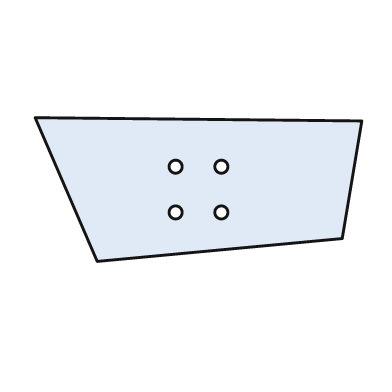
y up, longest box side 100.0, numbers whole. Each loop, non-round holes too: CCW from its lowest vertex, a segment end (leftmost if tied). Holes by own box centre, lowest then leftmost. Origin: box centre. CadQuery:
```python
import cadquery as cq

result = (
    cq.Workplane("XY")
    .moveTo(-31.0, -22.0)
    .lineTo(44.0, -15.0)
    .lineTo(50.0, 21.0)
    .lineTo(-50.0, 22.0)
    .close()
    .moveTo(-7.0, -7.0)
    .circle(2.0)
    .moveTo(7.0, -7.0)
    .circle(2.0)
    .moveTo(-7.0, 7.0)
    .circle(2.0)
    .moveTo(7.0, 7.0)
    .circle(2.0)
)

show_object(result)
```